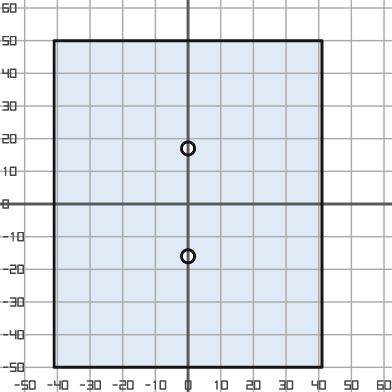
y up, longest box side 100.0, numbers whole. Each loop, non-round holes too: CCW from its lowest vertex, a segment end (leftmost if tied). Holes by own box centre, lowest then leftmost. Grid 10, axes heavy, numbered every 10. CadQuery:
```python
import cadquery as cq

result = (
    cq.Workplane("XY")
    .moveTo(-41.0, -50.0)
    .lineTo(41.0, -50.0)
    .lineTo(41.0, 50.0)
    .lineTo(-41.0, 50.0)
    .close()
    .moveTo(0.0, -16.0)
    .circle(2.0)
    .moveTo(0.0, 17.0)
    .circle(2.0)
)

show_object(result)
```